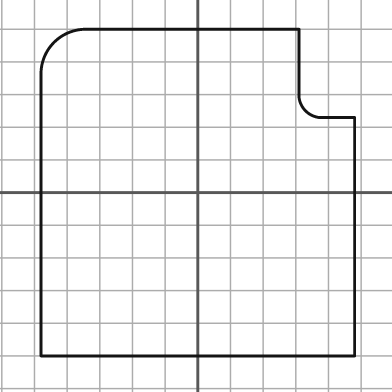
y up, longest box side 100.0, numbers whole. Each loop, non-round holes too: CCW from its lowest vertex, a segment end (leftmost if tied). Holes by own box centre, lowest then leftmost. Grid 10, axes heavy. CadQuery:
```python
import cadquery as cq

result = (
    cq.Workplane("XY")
    .moveTo(-48.0, -50.0)
    .lineTo(48.0, -50.0)
    .lineTo(48.0, 23.0)
    .lineTo(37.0, 23.0)
    .threePointArc((33.0, 25.0), (31.0, 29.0))
    .lineTo(31.0, 50.0)
    .lineTo(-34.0, 50.0)
    .threePointArc((-44.0, 46.0), (-48.0, 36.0))
    .close()
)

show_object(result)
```